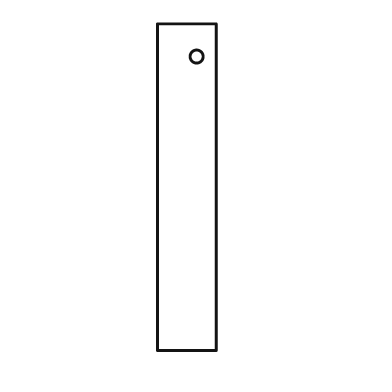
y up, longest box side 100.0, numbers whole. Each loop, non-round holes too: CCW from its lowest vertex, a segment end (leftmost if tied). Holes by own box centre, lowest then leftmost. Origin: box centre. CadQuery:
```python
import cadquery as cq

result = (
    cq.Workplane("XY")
    .moveTo(-9.0, -50.0)
    .lineTo(9.0, -50.0)
    .lineTo(9.0, 50.0)
    .lineTo(-9.0, 50.0)
    .close()
    .moveTo(3.0, 40.0)
    .circle(2.0)
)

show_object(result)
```